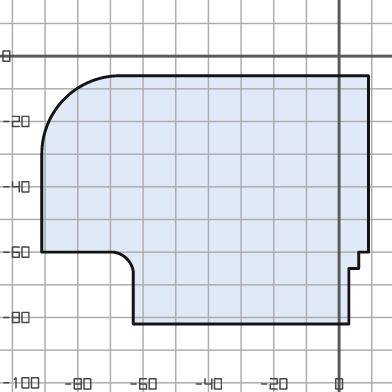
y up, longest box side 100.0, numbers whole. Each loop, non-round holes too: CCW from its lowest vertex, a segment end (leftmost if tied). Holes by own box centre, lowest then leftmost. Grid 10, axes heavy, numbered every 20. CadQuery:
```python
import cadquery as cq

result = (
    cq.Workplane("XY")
    .moveTo(-63.0, -82.0)
    .lineTo(3.0, -82.0)
    .lineTo(3.0, -65.0)
    .lineTo(6.0, -65.0)
    .lineTo(6.0, -60.0)
    .lineTo(9.0, -60.0)
    .lineTo(9.0, -6.0)
    .lineTo(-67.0, -6.0)
    .threePointArc((-84.0, -13.0), (-91.0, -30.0))
    .lineTo(-91.0, -60.0)
    .lineTo(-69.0, -60.0)
    .threePointArc((-65.0, -62.0), (-63.0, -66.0))
    .close()
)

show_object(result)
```